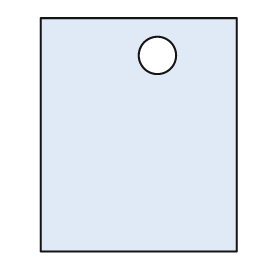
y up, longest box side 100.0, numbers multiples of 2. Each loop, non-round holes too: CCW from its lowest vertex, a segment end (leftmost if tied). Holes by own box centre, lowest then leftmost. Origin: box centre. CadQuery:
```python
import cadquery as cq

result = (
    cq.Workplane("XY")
    .moveTo(-42.0, -50.0)
    .lineTo(42.0, -50.0)
    .lineTo(42.0, 50.0)
    .lineTo(-42.0, 50.0)
    .close()
    .moveTo(8.0, 34.0)
    .circle(8.0)
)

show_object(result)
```